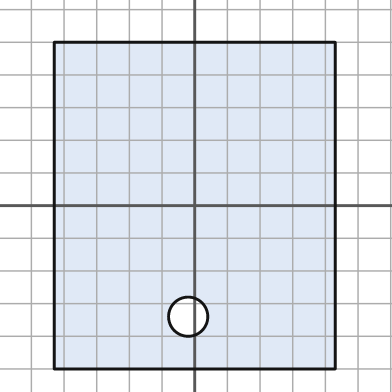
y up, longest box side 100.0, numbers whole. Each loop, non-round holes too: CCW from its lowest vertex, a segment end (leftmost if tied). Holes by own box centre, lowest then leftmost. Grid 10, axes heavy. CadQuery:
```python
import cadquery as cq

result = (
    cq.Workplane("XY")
    .moveTo(-43.0, -50.0)
    .lineTo(43.0, -50.0)
    .lineTo(43.0, 50.0)
    .lineTo(-43.0, 50.0)
    .close()
    .moveTo(-2.0, -34.0)
    .circle(6.0)
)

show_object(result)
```